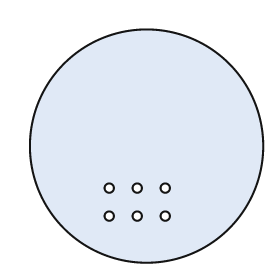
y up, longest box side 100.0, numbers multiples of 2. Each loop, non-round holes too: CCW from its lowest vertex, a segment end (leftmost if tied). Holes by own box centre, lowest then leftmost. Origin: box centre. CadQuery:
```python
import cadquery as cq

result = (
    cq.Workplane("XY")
    .moveTo(0.0, 0.0)
    .circle(50.0)
    .moveTo(-16.0, -30.0)
    .circle(2.0)
    .moveTo(-4.0, -30.0)
    .circle(2.0)
    .moveTo(8.0, -30.0)
    .circle(2.0)
    .moveTo(-16.0, -18.0)
    .circle(2.0)
    .moveTo(-4.0, -18.0)
    .circle(2.0)
    .moveTo(8.0, -18.0)
    .circle(2.0)
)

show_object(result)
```